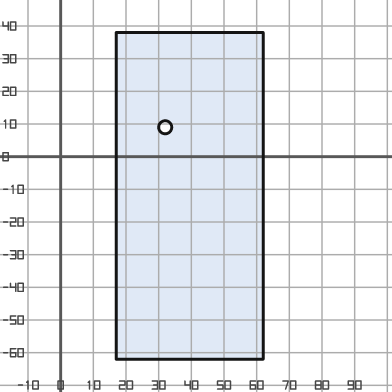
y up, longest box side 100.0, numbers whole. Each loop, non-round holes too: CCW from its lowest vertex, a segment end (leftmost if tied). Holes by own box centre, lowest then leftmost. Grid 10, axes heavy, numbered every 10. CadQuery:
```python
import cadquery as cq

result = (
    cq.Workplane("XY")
    .moveTo(17.0, -62.0)
    .lineTo(62.0, -62.0)
    .lineTo(62.0, 38.0)
    .lineTo(17.0, 38.0)
    .close()
    .moveTo(32.0, 9.0)
    .circle(2.0)
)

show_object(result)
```